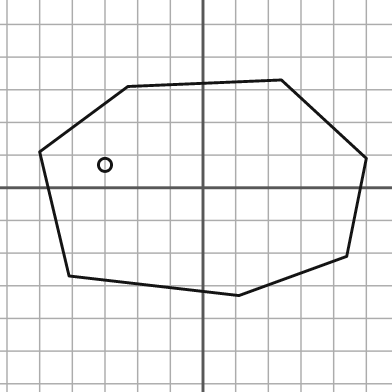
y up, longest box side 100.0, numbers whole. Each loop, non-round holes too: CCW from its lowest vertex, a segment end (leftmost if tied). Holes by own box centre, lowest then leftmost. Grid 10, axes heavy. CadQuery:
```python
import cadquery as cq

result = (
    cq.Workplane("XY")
    .moveTo(11.0, -33.0)
    .lineTo(44.0, -21.0)
    .lineTo(50.0, 9.0)
    .lineTo(24.0, 33.0)
    .lineTo(-23.0, 31.0)
    .lineTo(-50.0, 11.0)
    .lineTo(-41.0, -27.0)
    .close()
    .moveTo(-30.0, 7.0)
    .circle(2.0)
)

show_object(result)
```